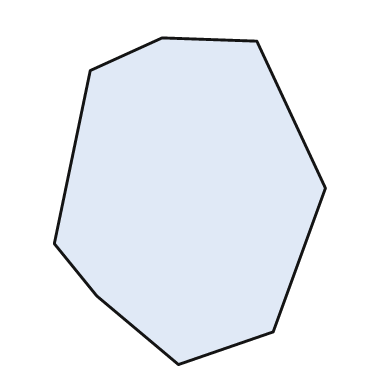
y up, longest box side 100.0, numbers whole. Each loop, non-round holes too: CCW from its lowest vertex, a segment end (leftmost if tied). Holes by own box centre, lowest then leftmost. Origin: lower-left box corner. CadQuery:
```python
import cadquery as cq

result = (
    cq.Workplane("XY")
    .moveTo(38.0, 0.0)
    .lineTo(67.0, 10.0)
    .lineTo(83.0, 54.0)
    .lineTo(62.0, 99.0)
    .lineTo(33.0, 100.0)
    .lineTo(11.0, 90.0)
    .lineTo(0.0, 37.0)
    .lineTo(13.0, 21.0)
    .close()
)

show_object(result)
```